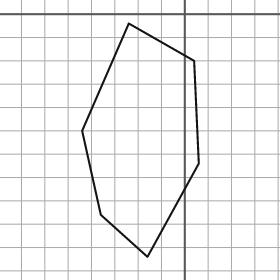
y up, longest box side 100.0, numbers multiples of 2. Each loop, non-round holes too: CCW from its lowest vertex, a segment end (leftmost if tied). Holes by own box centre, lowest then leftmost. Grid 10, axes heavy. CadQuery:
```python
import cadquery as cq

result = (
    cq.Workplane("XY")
    .moveTo(-16.0, -104.0)
    .lineTo(6.0, -64.0)
    .lineTo(4.0, -20.0)
    .lineTo(-24.0, -4.0)
    .lineTo(-44.0, -50.0)
    .lineTo(-36.0, -86.0)
    .close()
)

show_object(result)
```